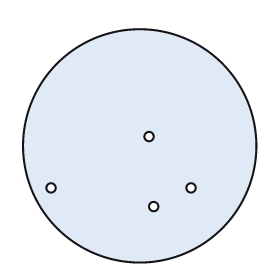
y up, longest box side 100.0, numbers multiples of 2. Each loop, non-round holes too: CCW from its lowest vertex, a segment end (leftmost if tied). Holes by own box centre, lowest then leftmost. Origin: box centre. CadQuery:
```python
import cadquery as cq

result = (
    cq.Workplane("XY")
    .moveTo(0.0, 0.0)
    .circle(50.0)
    .moveTo(6.0, -26.0)
    .circle(2.0)
    .moveTo(-38.0, -18.0)
    .circle(2.0)
    .moveTo(22.0, -18.0)
    .circle(2.0)
    .moveTo(4.0, 4.0)
    .circle(2.0)
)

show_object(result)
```